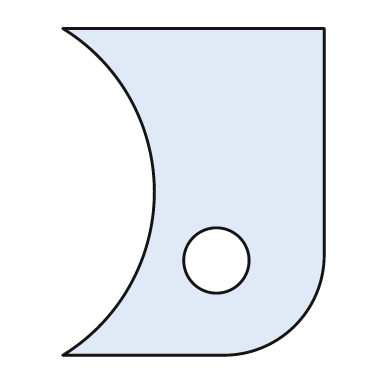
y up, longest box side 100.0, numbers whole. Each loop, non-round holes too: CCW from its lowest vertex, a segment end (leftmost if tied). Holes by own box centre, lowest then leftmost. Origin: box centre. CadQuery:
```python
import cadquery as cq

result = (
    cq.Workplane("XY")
    .moveTo(-40.0, -50.0)
    .lineTo(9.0, -50.0)
    .threePointArc((31.0, -41.0), (40.0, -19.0))
    .lineTo(40.0, 50.0)
    .lineTo(-40.0, 50.0)
    .threePointArc((-12.0, 0.0), (-40.0, -50.0))
    .close()
    .moveTo(7.0, -21.0)
    .circle(10.0)
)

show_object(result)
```